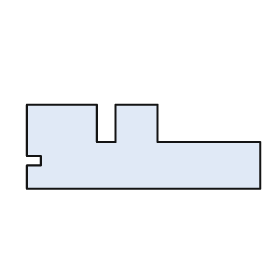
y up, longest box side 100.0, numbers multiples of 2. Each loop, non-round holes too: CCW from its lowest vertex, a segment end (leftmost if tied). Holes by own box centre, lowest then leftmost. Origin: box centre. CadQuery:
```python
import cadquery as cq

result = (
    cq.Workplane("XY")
    .moveTo(-50.0, -18.0)
    .lineTo(50.0, -18.0)
    .lineTo(50.0, 2.0)
    .lineTo(6.0, 2.0)
    .lineTo(6.0, 18.0)
    .lineTo(-12.0, 18.0)
    .lineTo(-12.0, 2.0)
    .lineTo(-20.0, 2.0)
    .lineTo(-20.0, 18.0)
    .lineTo(-50.0, 18.0)
    .lineTo(-50.0, -4.0)
    .lineTo(-44.0, -4.0)
    .lineTo(-44.0, -8.0)
    .lineTo(-50.0, -8.0)
    .close()
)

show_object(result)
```